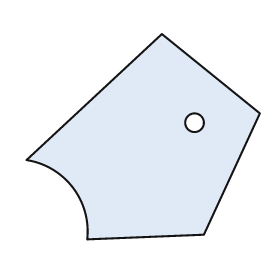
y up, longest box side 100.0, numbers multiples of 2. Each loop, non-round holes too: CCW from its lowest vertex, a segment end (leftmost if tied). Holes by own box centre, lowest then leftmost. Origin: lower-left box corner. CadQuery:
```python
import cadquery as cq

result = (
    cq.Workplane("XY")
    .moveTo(26.0, 0.0)
    .lineTo(76.0, 2.0)
    .lineTo(100.0, 54.0)
    .lineTo(58.0, 88.0)
    .lineTo(0.0, 34.0)
    .threePointArc((20.0, 22.0), (26.0, 0.0))
    .close()
    .moveTo(72.0, 50.0)
    .circle(4.0)
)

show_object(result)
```